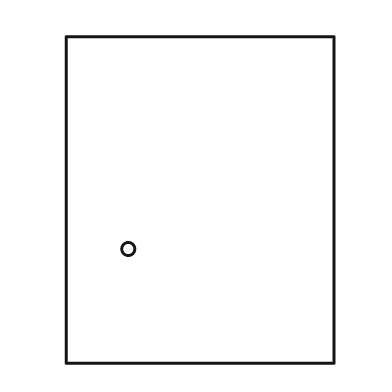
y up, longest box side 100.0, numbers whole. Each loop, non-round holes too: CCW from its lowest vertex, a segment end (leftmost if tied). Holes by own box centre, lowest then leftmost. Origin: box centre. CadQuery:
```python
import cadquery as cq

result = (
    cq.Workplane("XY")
    .moveTo(-41.0, -50.0)
    .lineTo(41.0, -50.0)
    .lineTo(41.0, 50.0)
    .lineTo(-41.0, 50.0)
    .close()
    .moveTo(-22.0, -15.0)
    .circle(2.0)
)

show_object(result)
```